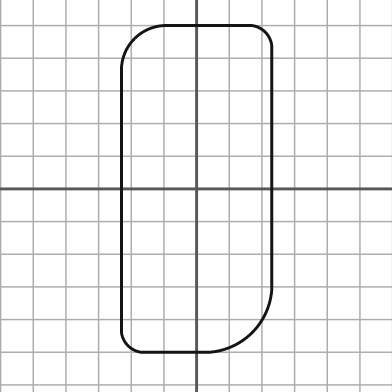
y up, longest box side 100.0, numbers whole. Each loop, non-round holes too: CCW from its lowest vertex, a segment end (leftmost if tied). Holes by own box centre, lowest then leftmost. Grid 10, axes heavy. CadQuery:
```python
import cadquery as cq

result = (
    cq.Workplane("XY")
    .moveTo(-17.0, -50.0)
    .lineTo(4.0, -50.0)
    .threePointArc((17.0, -44.0), (23.0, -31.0))
    .lineTo(23.0, 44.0)
    .threePointArc((21.0, 48.0), (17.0, 50.0))
    .lineTo(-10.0, 50.0)
    .threePointArc((-19.0, 46.0), (-23.0, 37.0))
    .lineTo(-23.0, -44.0)
    .threePointArc((-21.0, -48.0), (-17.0, -50.0))
    .close()
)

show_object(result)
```